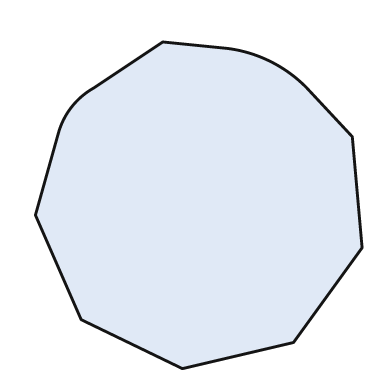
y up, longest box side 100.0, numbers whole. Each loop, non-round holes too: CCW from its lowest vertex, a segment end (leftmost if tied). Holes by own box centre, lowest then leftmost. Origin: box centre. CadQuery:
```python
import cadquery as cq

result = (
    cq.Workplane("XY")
    .moveTo(-5.0, -50.0)
    .lineTo(29.0, -42.0)
    .lineTo(50.0, -13.0)
    .lineTo(47.0, 21.0)
    .lineTo(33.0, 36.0)
    .threePointArc((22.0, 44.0), (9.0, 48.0))
    .lineTo(-11.0, 50.0)
    .lineTo(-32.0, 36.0)
    .threePointArc((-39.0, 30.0), (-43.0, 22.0))
    .lineTo(-50.0, -3.0)
    .lineTo(-36.0, -35.0)
    .close()
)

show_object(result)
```